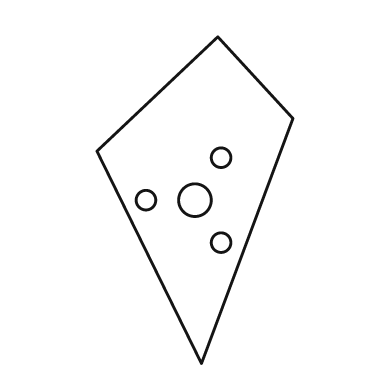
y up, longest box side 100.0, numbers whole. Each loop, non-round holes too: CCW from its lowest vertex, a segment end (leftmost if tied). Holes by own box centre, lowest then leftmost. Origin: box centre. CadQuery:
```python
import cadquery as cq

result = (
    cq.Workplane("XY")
    .moveTo(2.0, -50.0)
    .lineTo(30.0, 25.0)
    .lineTo(7.0, 50.0)
    .lineTo(-30.0, 15.0)
    .close()
    .moveTo(8.0, -13.0)
    .circle(3.0)
    .moveTo(-15.0, 0.0)
    .circle(3.0)
    .moveTo(0.0, 0.0)
    .circle(5.0)
    .moveTo(8.0, 13.0)
    .circle(3.0)
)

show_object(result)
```